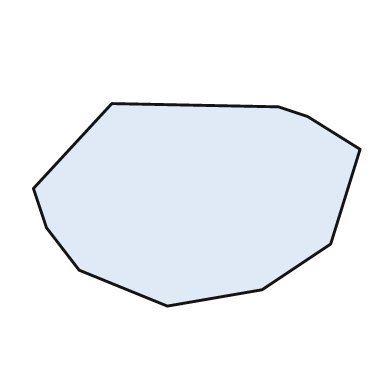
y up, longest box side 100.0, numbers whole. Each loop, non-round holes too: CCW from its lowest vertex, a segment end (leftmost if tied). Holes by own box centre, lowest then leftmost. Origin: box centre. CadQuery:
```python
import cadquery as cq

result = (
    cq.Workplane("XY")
    .moveTo(-9.0, -31.0)
    .lineTo(20.0, -26.0)
    .lineTo(41.0, -12.0)
    .lineTo(50.0, 17.0)
    .lineTo(34.0, 27.0)
    .lineTo(25.0, 30.0)
    .lineTo(-26.0, 31.0)
    .lineTo(-50.0, 5.0)
    .lineTo(-46.0, -7.0)
    .lineTo(-36.0, -20.0)
    .close()
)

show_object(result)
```